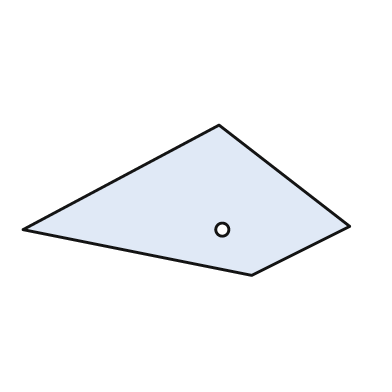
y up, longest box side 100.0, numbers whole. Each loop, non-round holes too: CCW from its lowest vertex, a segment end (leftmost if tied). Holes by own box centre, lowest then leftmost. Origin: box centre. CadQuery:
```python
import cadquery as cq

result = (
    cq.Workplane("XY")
    .moveTo(20.0, -23.0)
    .lineTo(50.0, -8.0)
    .lineTo(10.0, 23.0)
    .lineTo(-50.0, -9.0)
    .close()
    .moveTo(11.0, -9.0)
    .circle(2.0)
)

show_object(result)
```